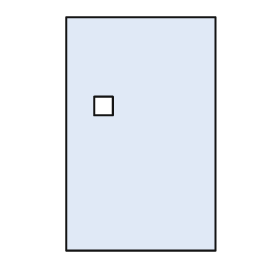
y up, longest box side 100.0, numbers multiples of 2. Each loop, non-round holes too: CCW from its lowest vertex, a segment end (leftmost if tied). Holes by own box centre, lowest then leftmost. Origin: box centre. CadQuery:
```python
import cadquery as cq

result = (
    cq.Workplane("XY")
    .moveTo(-32.0, -50.0)
    .lineTo(32.0, -50.0)
    .lineTo(32.0, 50.0)
    .lineTo(-32.0, 50.0)
    .close()
    .moveTo(-20.0, 8.0)
    .lineTo(-12.0, 8.0)
    .lineTo(-12.0, 16.0)
    .lineTo(-20.0, 16.0)
    .close()
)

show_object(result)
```